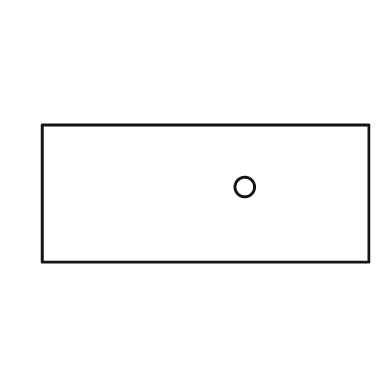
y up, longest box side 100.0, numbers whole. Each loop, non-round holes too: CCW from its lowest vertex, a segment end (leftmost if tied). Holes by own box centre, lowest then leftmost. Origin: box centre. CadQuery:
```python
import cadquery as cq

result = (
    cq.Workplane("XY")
    .moveTo(-50.0, -21.0)
    .lineTo(50.0, -21.0)
    .lineTo(50.0, 21.0)
    .lineTo(-50.0, 21.0)
    .close()
    .moveTo(12.0, 2.0)
    .circle(3.0)
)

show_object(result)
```